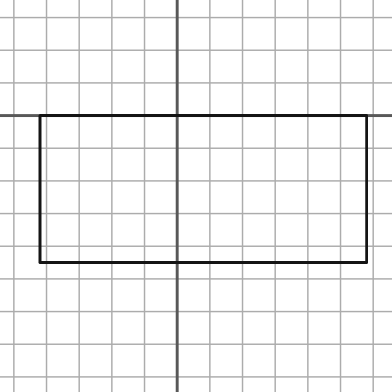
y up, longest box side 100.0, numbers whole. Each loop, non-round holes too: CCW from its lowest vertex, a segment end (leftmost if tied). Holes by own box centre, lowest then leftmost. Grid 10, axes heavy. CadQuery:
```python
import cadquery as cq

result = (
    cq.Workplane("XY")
    .moveTo(-42.0, -45.0)
    .lineTo(58.0, -45.0)
    .lineTo(58.0, 0.0)
    .lineTo(-42.0, 0.0)
    .close()
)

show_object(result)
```